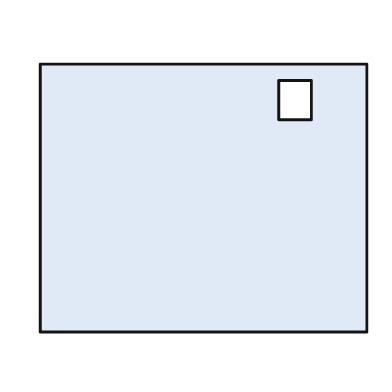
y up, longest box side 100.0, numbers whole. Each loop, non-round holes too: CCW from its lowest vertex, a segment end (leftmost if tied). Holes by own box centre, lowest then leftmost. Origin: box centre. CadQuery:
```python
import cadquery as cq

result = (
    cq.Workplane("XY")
    .moveTo(-50.0, -41.0)
    .lineTo(50.0, -41.0)
    .lineTo(50.0, 41.0)
    .lineTo(-50.0, 41.0)
    .close()
    .moveTo(23.0, 24.0)
    .lineTo(33.0, 24.0)
    .lineTo(33.0, 36.0)
    .lineTo(23.0, 36.0)
    .close()
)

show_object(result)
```